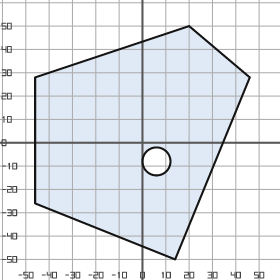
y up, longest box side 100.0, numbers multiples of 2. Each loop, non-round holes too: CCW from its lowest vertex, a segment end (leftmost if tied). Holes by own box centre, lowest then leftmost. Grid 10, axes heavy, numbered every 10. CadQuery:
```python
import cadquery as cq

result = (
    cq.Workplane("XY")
    .moveTo(14.0, -50.0)
    .lineTo(46.0, 28.0)
    .lineTo(20.0, 50.0)
    .lineTo(-46.0, 28.0)
    .lineTo(-46.0, -26.0)
    .close()
    .moveTo(6.0, -8.0)
    .circle(6.0)
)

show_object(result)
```